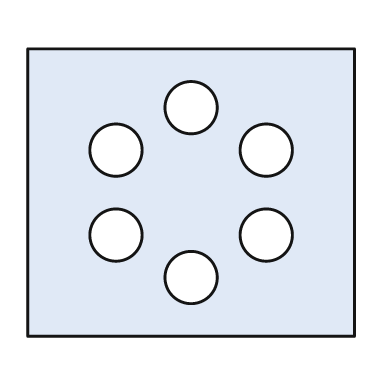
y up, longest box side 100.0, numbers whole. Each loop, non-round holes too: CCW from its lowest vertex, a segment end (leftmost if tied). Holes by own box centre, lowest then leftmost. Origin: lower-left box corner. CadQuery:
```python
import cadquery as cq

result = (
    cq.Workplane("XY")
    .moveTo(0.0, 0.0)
    .lineTo(100.0, 0.0)
    .lineTo(100.0, 88.0)
    .lineTo(0.0, 88.0)
    .close()
    .moveTo(50.0, 18.0)
    .circle(8.0)
    .moveTo(27.0, 31.0)
    .circle(8.0)
    .moveTo(73.0, 31.0)
    .circle(8.0)
    .moveTo(27.0, 57.0)
    .circle(8.0)
    .moveTo(73.0, 57.0)
    .circle(8.0)
    .moveTo(50.0, 70.0)
    .circle(8.0)
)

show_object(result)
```